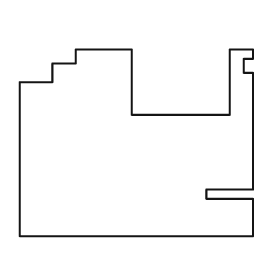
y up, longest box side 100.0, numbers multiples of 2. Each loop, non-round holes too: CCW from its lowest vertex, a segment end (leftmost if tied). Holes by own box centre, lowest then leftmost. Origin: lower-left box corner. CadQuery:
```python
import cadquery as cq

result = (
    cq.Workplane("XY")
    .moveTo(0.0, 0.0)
    .lineTo(100.0, 0.0)
    .lineTo(100.0, 16.0)
    .lineTo(80.0, 16.0)
    .lineTo(80.0, 20.0)
    .lineTo(100.0, 20.0)
    .lineTo(100.0, 70.0)
    .lineTo(96.0, 70.0)
    .lineTo(96.0, 76.0)
    .lineTo(100.0, 76.0)
    .lineTo(100.0, 80.0)
    .lineTo(90.0, 80.0)
    .lineTo(90.0, 52.0)
    .lineTo(48.0, 52.0)
    .lineTo(48.0, 80.0)
    .lineTo(24.0, 80.0)
    .lineTo(24.0, 74.0)
    .lineTo(14.0, 74.0)
    .lineTo(14.0, 66.0)
    .lineTo(0.0, 66.0)
    .close()
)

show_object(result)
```